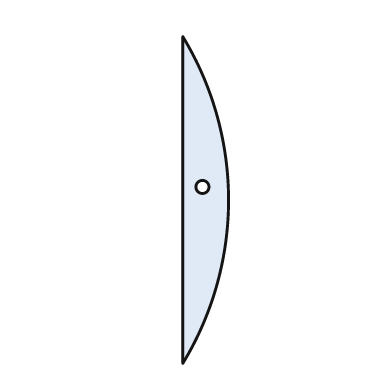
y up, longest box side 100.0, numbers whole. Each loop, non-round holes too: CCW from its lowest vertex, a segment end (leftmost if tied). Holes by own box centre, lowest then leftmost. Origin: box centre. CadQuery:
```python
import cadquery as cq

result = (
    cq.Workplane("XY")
    .moveTo(-7.0, -50.0)
    .threePointArc((7.0, 0.0), (-7.0, 50.0))
    .close()
    .moveTo(-1.0, 4.0)
    .circle(2.0)
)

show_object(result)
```